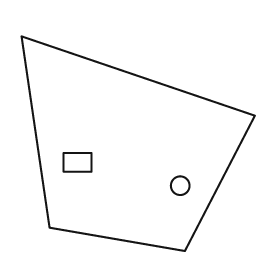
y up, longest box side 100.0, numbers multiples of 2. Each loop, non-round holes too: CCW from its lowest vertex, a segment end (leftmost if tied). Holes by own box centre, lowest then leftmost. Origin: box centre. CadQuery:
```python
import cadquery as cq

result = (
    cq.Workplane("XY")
    .moveTo(20.0, -46.0)
    .lineTo(50.0, 12.0)
    .lineTo(-50.0, 46.0)
    .lineTo(-38.0, -36.0)
    .close()
    .moveTo(18.0, -18.0)
    .circle(4.0)
    .moveTo(-32.0, -12.0)
    .lineTo(-20.0, -12.0)
    .lineTo(-20.0, -4.0)
    .lineTo(-32.0, -4.0)
    .close()
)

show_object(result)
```